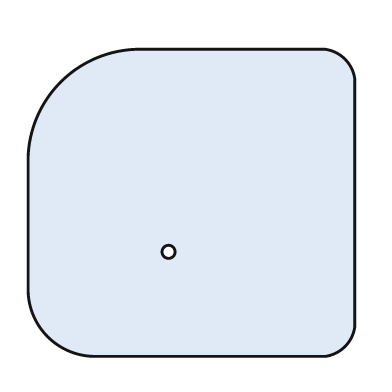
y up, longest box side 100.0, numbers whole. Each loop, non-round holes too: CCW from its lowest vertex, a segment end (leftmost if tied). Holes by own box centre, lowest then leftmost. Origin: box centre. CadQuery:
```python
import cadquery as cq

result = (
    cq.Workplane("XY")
    .moveTo(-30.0, -47.0)
    .lineTo(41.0, -47.0)
    .threePointArc((47.0, -44.0), (50.0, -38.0))
    .lineTo(50.0, 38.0)
    .threePointArc((47.0, 44.0), (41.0, 47.0))
    .lineTo(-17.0, 47.0)
    .threePointArc((-40.0, 37.0), (-50.0, 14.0))
    .lineTo(-50.0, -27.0)
    .threePointArc((-44.0, -41.0), (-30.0, -47.0))
    .close()
    .moveTo(-7.0, -15.0)
    .circle(2.0)
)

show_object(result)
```